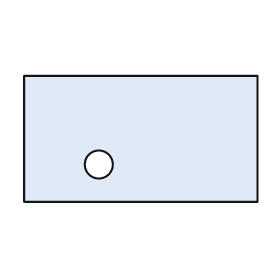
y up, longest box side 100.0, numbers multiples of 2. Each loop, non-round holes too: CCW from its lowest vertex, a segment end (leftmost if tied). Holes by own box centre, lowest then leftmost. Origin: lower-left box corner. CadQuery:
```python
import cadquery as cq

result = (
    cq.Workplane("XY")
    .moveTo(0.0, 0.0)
    .lineTo(100.0, 0.0)
    .lineTo(100.0, 54.0)
    .lineTo(0.0, 54.0)
    .close()
    .moveTo(32.0, 16.0)
    .circle(6.0)
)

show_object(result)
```